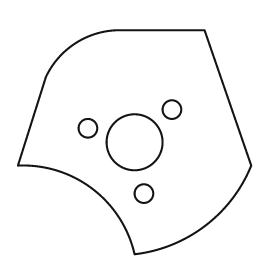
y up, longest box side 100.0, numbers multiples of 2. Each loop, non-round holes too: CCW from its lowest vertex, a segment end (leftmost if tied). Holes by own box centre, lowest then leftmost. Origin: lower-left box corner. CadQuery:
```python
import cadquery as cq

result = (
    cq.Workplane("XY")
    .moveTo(50.0, 0.0)
    .threePointArc((80.0, 12.0), (100.0, 38.0))
    .lineTo(80.0, 96.0)
    .lineTo(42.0, 96.0)
    .threePointArc((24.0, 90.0), (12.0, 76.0))
    .lineTo(0.0, 38.0)
    .threePointArc((32.0, 28.0), (50.0, 0.0))
    .close()
    .moveTo(54.0, 26.0)
    .circle(4.0)
    .moveTo(50.0, 48.0)
    .circle(12.0)
    .moveTo(30.0, 54.0)
    .circle(4.0)
    .moveTo(66.0, 62.0)
    .circle(4.0)
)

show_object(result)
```